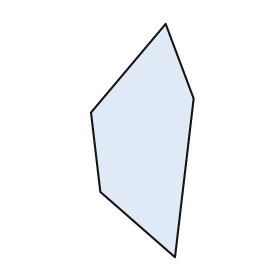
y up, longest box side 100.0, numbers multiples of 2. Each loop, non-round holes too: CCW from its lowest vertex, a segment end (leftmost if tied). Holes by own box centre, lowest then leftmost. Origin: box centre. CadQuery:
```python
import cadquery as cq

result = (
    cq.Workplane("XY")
    .moveTo(14.0, -50.0)
    .lineTo(22.0, 18.0)
    .lineTo(10.0, 50.0)
    .lineTo(-22.0, 12.0)
    .lineTo(-18.0, -22.0)
    .close()
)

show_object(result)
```